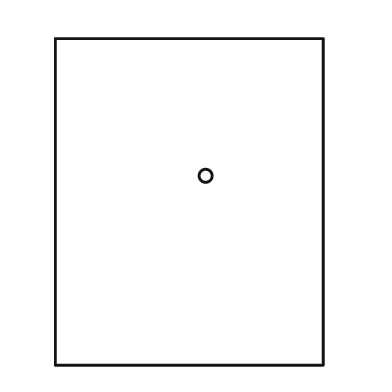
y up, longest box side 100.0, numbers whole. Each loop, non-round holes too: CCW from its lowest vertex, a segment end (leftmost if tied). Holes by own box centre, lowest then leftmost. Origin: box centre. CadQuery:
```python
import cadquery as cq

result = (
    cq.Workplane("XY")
    .moveTo(-41.0, -50.0)
    .lineTo(41.0, -50.0)
    .lineTo(41.0, 50.0)
    .lineTo(-41.0, 50.0)
    .close()
    .moveTo(5.0, 8.0)
    .circle(2.0)
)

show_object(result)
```